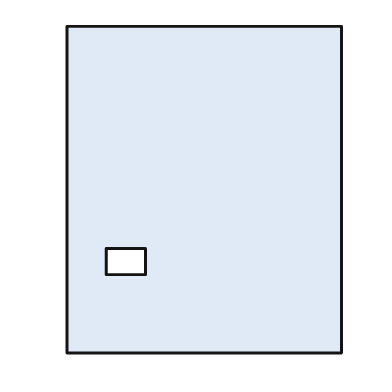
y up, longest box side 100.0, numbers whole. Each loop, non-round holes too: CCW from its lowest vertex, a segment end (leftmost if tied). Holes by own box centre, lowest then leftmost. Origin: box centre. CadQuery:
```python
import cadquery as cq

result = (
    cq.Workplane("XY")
    .moveTo(-42.0, -50.0)
    .lineTo(42.0, -50.0)
    .lineTo(42.0, 50.0)
    .lineTo(-42.0, 50.0)
    .close()
    .moveTo(-30.0, -26.0)
    .lineTo(-18.0, -26.0)
    .lineTo(-18.0, -18.0)
    .lineTo(-30.0, -18.0)
    .close()
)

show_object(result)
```